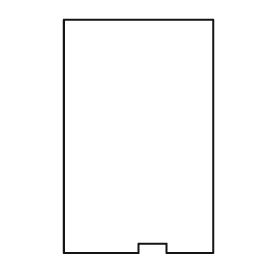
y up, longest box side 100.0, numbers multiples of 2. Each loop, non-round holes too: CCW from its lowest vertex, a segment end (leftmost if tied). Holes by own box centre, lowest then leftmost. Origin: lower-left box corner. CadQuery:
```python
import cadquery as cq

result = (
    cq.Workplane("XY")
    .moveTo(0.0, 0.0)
    .lineTo(32.0, 0.0)
    .lineTo(32.0, 4.0)
    .lineTo(44.0, 4.0)
    .lineTo(44.0, 0.0)
    .lineTo(64.0, 0.0)
    .lineTo(64.0, 100.0)
    .lineTo(0.0, 100.0)
    .close()
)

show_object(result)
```